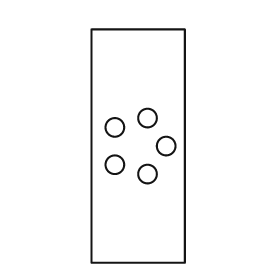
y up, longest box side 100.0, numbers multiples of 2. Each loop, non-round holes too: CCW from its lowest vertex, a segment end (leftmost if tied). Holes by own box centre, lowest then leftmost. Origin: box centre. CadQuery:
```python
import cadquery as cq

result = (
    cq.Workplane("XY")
    .moveTo(-20.0, -50.0)
    .lineTo(20.0, -50.0)
    .lineTo(20.0, 50.0)
    .lineTo(-20.0, 50.0)
    .close()
    .moveTo(4.0, -12.0)
    .circle(4.0)
    .moveTo(-10.0, -8.0)
    .circle(4.0)
    .moveTo(12.0, 0.0)
    .circle(4.0)
    .moveTo(-10.0, 8.0)
    .circle(4.0)
    .moveTo(4.0, 12.0)
    .circle(4.0)
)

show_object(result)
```